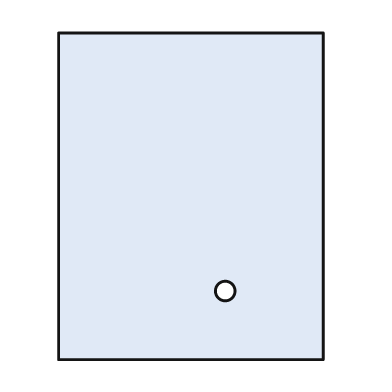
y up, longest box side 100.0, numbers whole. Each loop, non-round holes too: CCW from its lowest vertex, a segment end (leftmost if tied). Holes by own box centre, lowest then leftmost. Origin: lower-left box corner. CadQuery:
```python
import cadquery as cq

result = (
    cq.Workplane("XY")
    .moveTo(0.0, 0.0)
    .lineTo(81.0, 0.0)
    .lineTo(81.0, 100.0)
    .lineTo(0.0, 100.0)
    .close()
    .moveTo(51.0, 21.0)
    .circle(3.0)
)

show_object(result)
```